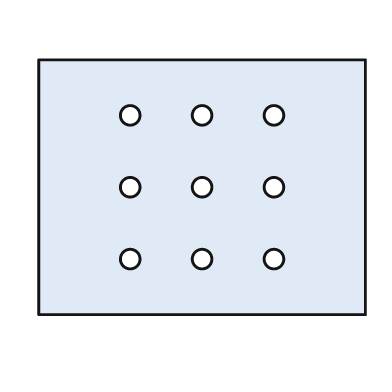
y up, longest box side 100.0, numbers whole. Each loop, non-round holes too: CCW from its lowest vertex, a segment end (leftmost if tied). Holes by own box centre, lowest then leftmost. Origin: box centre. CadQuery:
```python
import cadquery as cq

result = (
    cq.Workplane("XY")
    .moveTo(-50.0, -39.0)
    .lineTo(50.0, -39.0)
    .lineTo(50.0, 39.0)
    .lineTo(-50.0, 39.0)
    .close()
    .moveTo(-22.0, -22.0)
    .circle(3.0)
    .moveTo(0.0, -22.0)
    .circle(3.0)
    .moveTo(22.0, -22.0)
    .circle(3.0)
    .moveTo(-22.0, 0.0)
    .circle(3.0)
    .moveTo(0.0, 0.0)
    .circle(3.0)
    .moveTo(22.0, 0.0)
    .circle(3.0)
    .moveTo(-22.0, 22.0)
    .circle(3.0)
    .moveTo(0.0, 22.0)
    .circle(3.0)
    .moveTo(22.0, 22.0)
    .circle(3.0)
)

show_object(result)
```